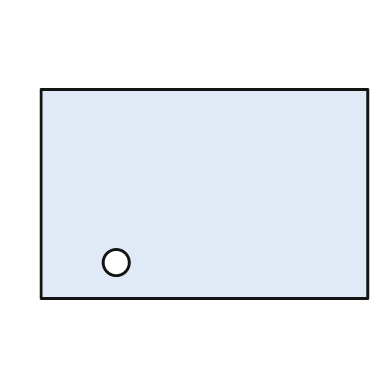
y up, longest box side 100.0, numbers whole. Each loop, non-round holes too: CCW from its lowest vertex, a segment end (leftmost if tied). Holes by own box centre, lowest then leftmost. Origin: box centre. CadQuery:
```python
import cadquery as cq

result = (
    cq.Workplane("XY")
    .moveTo(-50.0, -32.0)
    .lineTo(50.0, -32.0)
    .lineTo(50.0, 32.0)
    .lineTo(-50.0, 32.0)
    .close()
    .moveTo(-27.0, -21.0)
    .circle(4.0)
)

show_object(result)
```